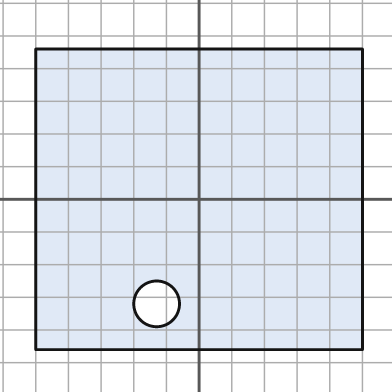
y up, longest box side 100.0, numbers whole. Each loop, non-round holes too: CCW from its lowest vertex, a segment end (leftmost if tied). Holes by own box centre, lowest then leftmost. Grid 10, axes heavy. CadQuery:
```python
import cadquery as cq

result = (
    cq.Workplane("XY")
    .moveTo(-50.0, -46.0)
    .lineTo(50.0, -46.0)
    .lineTo(50.0, 46.0)
    .lineTo(-50.0, 46.0)
    .close()
    .moveTo(-13.0, -32.0)
    .circle(7.0)
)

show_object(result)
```